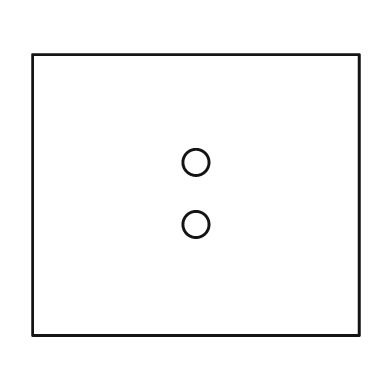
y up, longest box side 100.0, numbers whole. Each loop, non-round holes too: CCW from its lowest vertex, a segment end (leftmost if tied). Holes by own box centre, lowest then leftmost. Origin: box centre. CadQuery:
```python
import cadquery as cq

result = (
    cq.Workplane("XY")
    .moveTo(-50.0, -43.0)
    .lineTo(50.0, -43.0)
    .lineTo(50.0, 43.0)
    .lineTo(-50.0, 43.0)
    .close()
    .moveTo(0.0, -9.0)
    .circle(4.0)
    .moveTo(0.0, 10.0)
    .circle(4.0)
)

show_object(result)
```